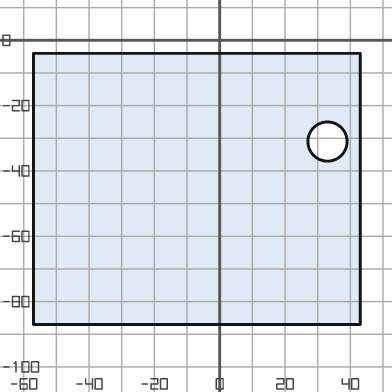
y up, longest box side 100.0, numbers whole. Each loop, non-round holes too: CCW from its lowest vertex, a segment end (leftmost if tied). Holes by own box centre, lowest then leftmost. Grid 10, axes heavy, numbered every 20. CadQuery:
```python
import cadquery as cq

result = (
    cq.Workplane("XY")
    .moveTo(-57.0, -87.0)
    .lineTo(43.0, -87.0)
    .lineTo(43.0, -4.0)
    .lineTo(-57.0, -4.0)
    .close()
    .moveTo(33.0, -31.0)
    .circle(6.0)
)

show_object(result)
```